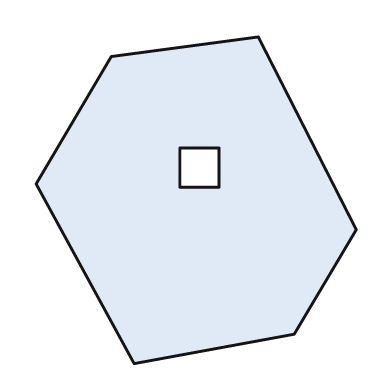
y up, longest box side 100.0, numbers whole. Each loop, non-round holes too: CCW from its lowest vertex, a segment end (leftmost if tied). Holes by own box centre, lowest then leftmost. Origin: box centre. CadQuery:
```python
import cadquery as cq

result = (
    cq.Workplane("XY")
    .moveTo(-19.0, -50.0)
    .lineTo(30.0, -41.0)
    .lineTo(49.0, -9.0)
    .lineTo(19.0, 50.0)
    .lineTo(-26.0, 44.0)
    .lineTo(-49.0, 5.0)
    .close()
    .moveTo(-5.0, 4.0)
    .lineTo(7.0, 4.0)
    .lineTo(7.0, 16.0)
    .lineTo(-5.0, 16.0)
    .close()
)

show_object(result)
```